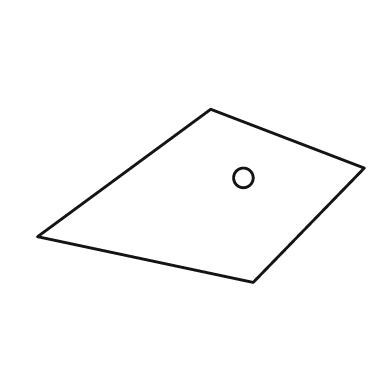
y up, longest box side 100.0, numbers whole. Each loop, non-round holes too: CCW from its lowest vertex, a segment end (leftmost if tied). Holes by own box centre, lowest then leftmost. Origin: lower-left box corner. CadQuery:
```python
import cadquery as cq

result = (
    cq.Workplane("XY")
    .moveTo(66.0, 0.0)
    .lineTo(100.0, 35.0)
    .lineTo(53.0, 53.0)
    .lineTo(0.0, 14.0)
    .close()
    .moveTo(63.0, 32.0)
    .circle(3.0)
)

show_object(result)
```